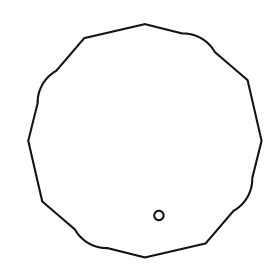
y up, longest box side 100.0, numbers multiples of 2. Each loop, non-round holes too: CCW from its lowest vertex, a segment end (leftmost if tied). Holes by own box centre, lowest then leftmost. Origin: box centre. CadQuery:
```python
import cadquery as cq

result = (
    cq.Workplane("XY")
    .moveTo(0.0, -50.0)
    .lineTo(26.0, -44.0)
    .lineTo(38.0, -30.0)
    .threePointArc((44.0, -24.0), (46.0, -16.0))
    .lineTo(50.0, 0.0)
    .lineTo(44.0, 26.0)
    .lineTo(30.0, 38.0)
    .threePointArc((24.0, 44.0), (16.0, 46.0))
    .lineTo(0.0, 50.0)
    .lineTo(-26.0, 44.0)
    .lineTo(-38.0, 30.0)
    .threePointArc((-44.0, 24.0), (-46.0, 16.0))
    .lineTo(-50.0, 0.0)
    .lineTo(-44.0, -26.0)
    .lineTo(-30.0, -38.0)
    .threePointArc((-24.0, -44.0), (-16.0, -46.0))
    .close()
    .moveTo(6.0, -32.0)
    .circle(2.0)
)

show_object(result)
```